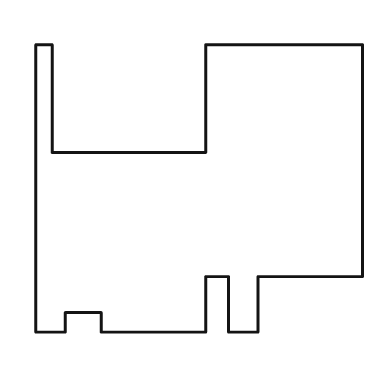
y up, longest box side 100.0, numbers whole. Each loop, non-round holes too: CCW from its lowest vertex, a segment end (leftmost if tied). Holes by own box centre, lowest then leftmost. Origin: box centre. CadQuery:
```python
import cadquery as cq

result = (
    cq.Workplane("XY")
    .moveTo(-50.0, -44.0)
    .lineTo(-41.0, -44.0)
    .lineTo(-41.0, -38.0)
    .lineTo(-30.0, -38.0)
    .lineTo(-30.0, -44.0)
    .lineTo(2.0, -44.0)
    .lineTo(2.0, -27.0)
    .lineTo(9.0, -27.0)
    .lineTo(9.0, -44.0)
    .lineTo(18.0, -44.0)
    .lineTo(18.0, -27.0)
    .lineTo(50.0, -27.0)
    .lineTo(50.0, 44.0)
    .lineTo(2.0, 44.0)
    .lineTo(2.0, 11.0)
    .lineTo(-45.0, 11.0)
    .lineTo(-45.0, 44.0)
    .lineTo(-50.0, 44.0)
    .close()
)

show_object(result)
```